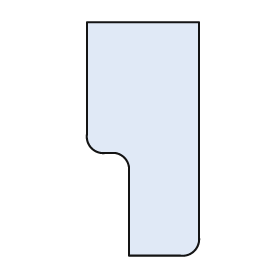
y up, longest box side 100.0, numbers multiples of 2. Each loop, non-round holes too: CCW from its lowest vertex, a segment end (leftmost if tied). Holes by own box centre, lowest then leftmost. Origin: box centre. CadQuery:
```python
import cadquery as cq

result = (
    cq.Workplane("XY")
    .moveTo(-6.0, -50.0)
    .lineTo(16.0, -50.0)
    .threePointArc((22.0, -48.0), (24.0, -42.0))
    .lineTo(24.0, 50.0)
    .lineTo(-24.0, 50.0)
    .lineTo(-24.0, 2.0)
    .threePointArc((-22.0, -4.0), (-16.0, -6.0))
    .lineTo(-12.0, -6.0)
    .threePointArc((-8.0, -8.0), (-6.0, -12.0))
    .close()
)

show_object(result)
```